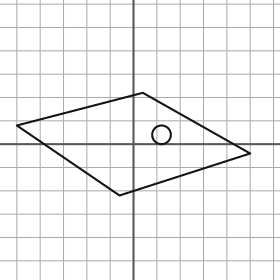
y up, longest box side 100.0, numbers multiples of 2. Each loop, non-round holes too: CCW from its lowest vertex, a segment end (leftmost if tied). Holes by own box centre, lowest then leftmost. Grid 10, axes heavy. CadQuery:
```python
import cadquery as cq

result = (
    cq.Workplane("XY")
    .moveTo(-6.0, -22.0)
    .lineTo(50.0, -4.0)
    .lineTo(4.0, 22.0)
    .lineTo(-50.0, 8.0)
    .close()
    .moveTo(12.0, 4.0)
    .circle(4.0)
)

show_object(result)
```